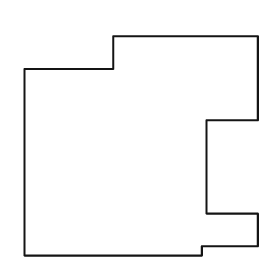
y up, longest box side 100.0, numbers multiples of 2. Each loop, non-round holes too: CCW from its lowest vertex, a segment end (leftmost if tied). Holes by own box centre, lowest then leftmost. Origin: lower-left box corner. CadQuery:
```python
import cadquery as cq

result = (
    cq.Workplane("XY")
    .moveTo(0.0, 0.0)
    .lineTo(76.0, 0.0)
    .lineTo(76.0, 4.0)
    .lineTo(100.0, 4.0)
    .lineTo(100.0, 18.0)
    .lineTo(78.0, 18.0)
    .lineTo(78.0, 58.0)
    .lineTo(100.0, 58.0)
    .lineTo(100.0, 94.0)
    .lineTo(38.0, 94.0)
    .lineTo(38.0, 80.0)
    .lineTo(0.0, 80.0)
    .close()
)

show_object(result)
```